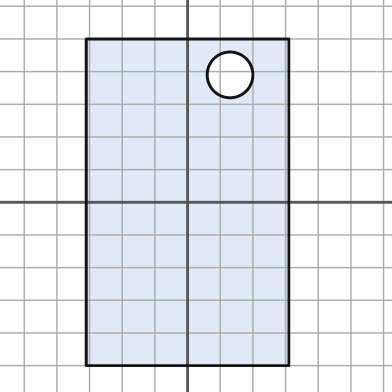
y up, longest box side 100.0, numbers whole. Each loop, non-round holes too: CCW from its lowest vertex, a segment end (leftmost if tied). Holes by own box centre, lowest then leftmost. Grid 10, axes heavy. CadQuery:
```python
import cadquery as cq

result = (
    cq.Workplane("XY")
    .moveTo(-31.0, -50.0)
    .lineTo(31.0, -50.0)
    .lineTo(31.0, 50.0)
    .lineTo(-31.0, 50.0)
    .close()
    .moveTo(13.0, 39.0)
    .circle(7.0)
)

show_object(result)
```